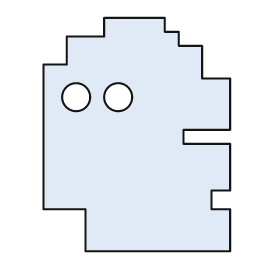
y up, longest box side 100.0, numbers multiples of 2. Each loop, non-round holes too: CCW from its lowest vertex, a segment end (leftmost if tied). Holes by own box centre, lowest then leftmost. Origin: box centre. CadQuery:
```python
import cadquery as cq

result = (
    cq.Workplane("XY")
    .moveTo(-22.0, -50.0)
    .lineTo(40.0, -50.0)
    .lineTo(40.0, -32.0)
    .lineTo(32.0, -32.0)
    .lineTo(32.0, -24.0)
    .lineTo(40.0, -24.0)
    .lineTo(40.0, -4.0)
    .lineTo(20.0, -4.0)
    .lineTo(20.0, 2.0)
    .lineTo(40.0, 2.0)
    .lineTo(40.0, 24.0)
    .lineTo(28.0, 24.0)
    .lineTo(28.0, 38.0)
    .lineTo(18.0, 38.0)
    .lineTo(18.0, 44.0)
    .lineTo(12.0, 44.0)
    .lineTo(12.0, 50.0)
    .lineTo(-14.0, 50.0)
    .lineTo(-14.0, 42.0)
    .lineTo(-30.0, 42.0)
    .lineTo(-30.0, 30.0)
    .lineTo(-40.0, 30.0)
    .lineTo(-40.0, -32.0)
    .lineTo(-22.0, -32.0)
    .close()
    .moveTo(-26.0, 16.0)
    .circle(6.0)
    .moveTo(-8.0, 16.0)
    .circle(6.0)
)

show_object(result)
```